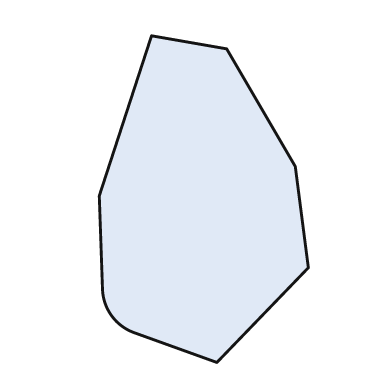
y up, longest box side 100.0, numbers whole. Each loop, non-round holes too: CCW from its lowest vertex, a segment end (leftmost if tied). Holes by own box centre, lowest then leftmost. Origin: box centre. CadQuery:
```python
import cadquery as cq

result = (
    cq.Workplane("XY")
    .moveTo(4.0, -50.0)
    .lineTo(32.0, -21.0)
    .lineTo(28.0, 10.0)
    .lineTo(7.0, 46.0)
    .lineTo(-16.0, 50.0)
    .lineTo(-32.0, 1.0)
    .lineTo(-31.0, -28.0)
    .threePointArc((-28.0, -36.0), (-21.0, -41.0))
    .close()
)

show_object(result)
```